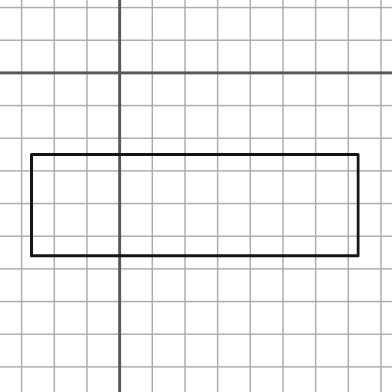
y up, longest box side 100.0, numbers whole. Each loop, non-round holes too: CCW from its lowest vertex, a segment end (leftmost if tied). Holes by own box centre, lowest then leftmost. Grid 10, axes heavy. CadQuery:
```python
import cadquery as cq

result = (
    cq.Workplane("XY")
    .moveTo(-27.0, -56.0)
    .lineTo(73.0, -56.0)
    .lineTo(73.0, -25.0)
    .lineTo(-27.0, -25.0)
    .close()
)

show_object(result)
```